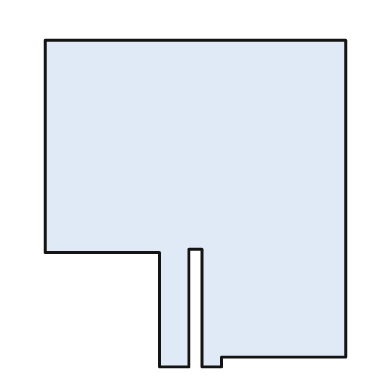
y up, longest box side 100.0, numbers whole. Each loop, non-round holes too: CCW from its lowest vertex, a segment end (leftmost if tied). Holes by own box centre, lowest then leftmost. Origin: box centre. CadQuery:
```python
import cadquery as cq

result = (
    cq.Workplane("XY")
    .moveTo(-11.0, -50.0)
    .lineTo(-2.0, -50.0)
    .lineTo(-2.0, -14.0)
    .lineTo(2.0, -14.0)
    .lineTo(2.0, -50.0)
    .lineTo(8.0, -50.0)
    .lineTo(8.0, -47.0)
    .lineTo(46.0, -47.0)
    .lineTo(46.0, 50.0)
    .lineTo(-46.0, 50.0)
    .lineTo(-46.0, -15.0)
    .lineTo(-11.0, -15.0)
    .close()
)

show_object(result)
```